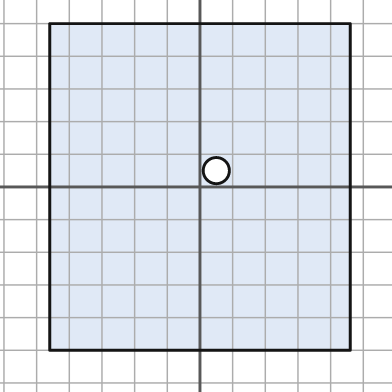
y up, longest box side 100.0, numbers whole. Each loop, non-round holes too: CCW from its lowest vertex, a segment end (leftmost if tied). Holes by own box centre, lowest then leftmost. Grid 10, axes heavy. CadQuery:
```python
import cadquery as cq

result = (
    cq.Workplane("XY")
    .moveTo(-46.0, -50.0)
    .lineTo(46.0, -50.0)
    .lineTo(46.0, 50.0)
    .lineTo(-46.0, 50.0)
    .close()
    .moveTo(5.0, 5.0)
    .circle(4.0)
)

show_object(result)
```